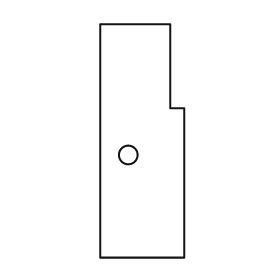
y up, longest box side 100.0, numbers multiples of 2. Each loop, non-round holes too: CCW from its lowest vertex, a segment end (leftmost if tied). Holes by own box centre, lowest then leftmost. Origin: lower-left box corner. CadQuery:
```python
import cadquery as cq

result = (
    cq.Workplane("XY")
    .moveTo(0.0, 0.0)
    .lineTo(36.0, 0.0)
    .lineTo(36.0, 64.0)
    .lineTo(30.0, 64.0)
    .lineTo(30.0, 100.0)
    .lineTo(0.0, 100.0)
    .close()
    .moveTo(12.0, 44.0)
    .circle(4.0)
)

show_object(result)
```